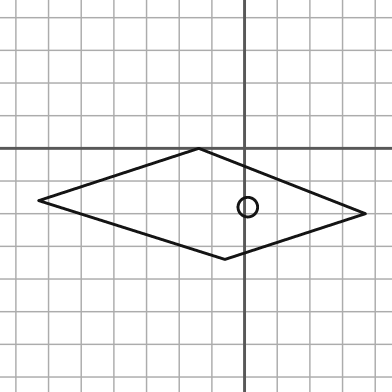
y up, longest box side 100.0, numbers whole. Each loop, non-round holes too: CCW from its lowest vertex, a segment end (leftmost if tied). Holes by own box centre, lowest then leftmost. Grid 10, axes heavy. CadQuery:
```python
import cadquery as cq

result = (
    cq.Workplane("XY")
    .moveTo(-6.0, -34.0)
    .lineTo(37.0, -20.0)
    .lineTo(-14.0, 0.0)
    .lineTo(-63.0, -16.0)
    .close()
    .moveTo(1.0, -18.0)
    .circle(3.0)
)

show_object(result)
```